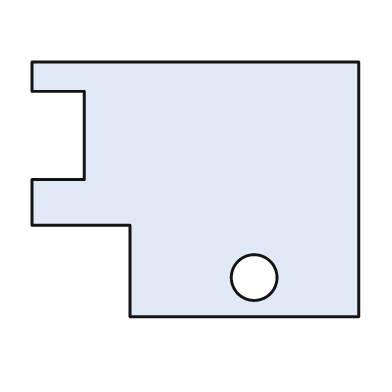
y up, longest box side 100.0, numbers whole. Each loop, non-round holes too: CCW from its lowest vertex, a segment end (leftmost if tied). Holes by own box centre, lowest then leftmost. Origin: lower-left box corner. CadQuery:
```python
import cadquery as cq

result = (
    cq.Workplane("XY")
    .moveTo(30.0, 0.0)
    .lineTo(100.0, 0.0)
    .lineTo(100.0, 78.0)
    .lineTo(0.0, 78.0)
    .lineTo(0.0, 69.0)
    .lineTo(16.0, 69.0)
    .lineTo(16.0, 42.0)
    .lineTo(0.0, 42.0)
    .lineTo(0.0, 28.0)
    .lineTo(30.0, 28.0)
    .close()
    .moveTo(68.0, 12.0)
    .circle(7.0)
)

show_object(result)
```